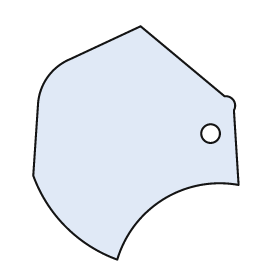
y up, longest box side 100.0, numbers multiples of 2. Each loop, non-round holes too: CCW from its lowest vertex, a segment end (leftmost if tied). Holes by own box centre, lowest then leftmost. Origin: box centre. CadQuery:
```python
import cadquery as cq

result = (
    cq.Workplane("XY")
    .moveTo(-8.0, -50.0)
    .threePointArc((12.0, -24.0), (44.0, -18.0))
    .lineTo(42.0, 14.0)
    .threePointArc((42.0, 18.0), (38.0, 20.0))
    .lineTo(2.0, 50.0)
    .lineTo(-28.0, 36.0)
    .threePointArc((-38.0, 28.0), (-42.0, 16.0))
    .lineTo(-44.0, -14.0)
    .threePointArc((-30.0, -36.0), (-8.0, -50.0))
    .close()
    .moveTo(32.0, 4.0)
    .circle(4.0)
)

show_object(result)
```